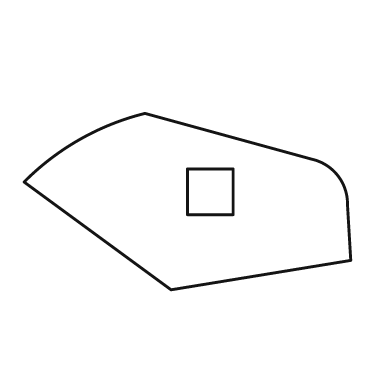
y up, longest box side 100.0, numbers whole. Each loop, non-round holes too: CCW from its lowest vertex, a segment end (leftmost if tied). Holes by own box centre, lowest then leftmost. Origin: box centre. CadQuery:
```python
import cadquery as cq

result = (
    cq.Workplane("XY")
    .moveTo(-5.0, -27.0)
    .lineTo(50.0, -18.0)
    .lineTo(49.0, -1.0)
    .threePointArc((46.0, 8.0), (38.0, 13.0))
    .lineTo(-13.0, 27.0)
    .threePointArc((-33.0, 19.0), (-50.0, 6.0))
    .close()
    .moveTo(0.0, -4.0)
    .lineTo(14.0, -4.0)
    .lineTo(14.0, 10.0)
    .lineTo(0.0, 10.0)
    .close()
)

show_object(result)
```